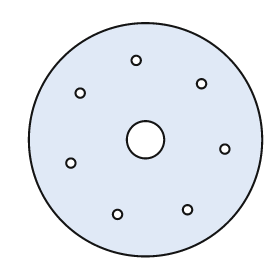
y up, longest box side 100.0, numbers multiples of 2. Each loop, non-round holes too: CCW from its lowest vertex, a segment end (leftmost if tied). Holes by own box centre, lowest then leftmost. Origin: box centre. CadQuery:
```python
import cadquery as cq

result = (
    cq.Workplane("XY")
    .moveTo(0.0, 0.0)
    .circle(50.0)
    .moveTo(-12.0, -32.0)
    .circle(2.0)
    .moveTo(18.0, -30.0)
    .circle(2.0)
    .moveTo(-32.0, -10.0)
    .circle(2.0)
    .moveTo(34.0, -4.0)
    .circle(2.0)
    .moveTo(0.0, 0.0)
    .circle(8.0)
    .moveTo(-28.0, 20.0)
    .circle(2.0)
    .moveTo(24.0, 24.0)
    .circle(2.0)
    .moveTo(-4.0, 34.0)
    .circle(2.0)
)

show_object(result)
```